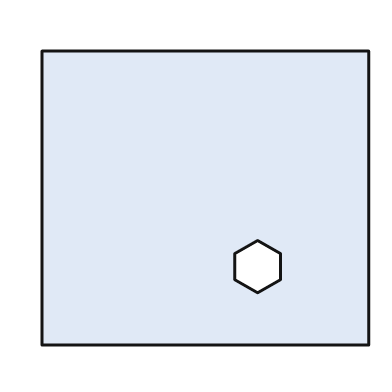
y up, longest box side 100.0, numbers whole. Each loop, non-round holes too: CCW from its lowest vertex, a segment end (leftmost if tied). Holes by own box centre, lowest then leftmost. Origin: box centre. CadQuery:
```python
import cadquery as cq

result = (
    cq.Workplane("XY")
    .moveTo(-50.0, -45.0)
    .lineTo(50.0, -45.0)
    .lineTo(50.0, 45.0)
    .lineTo(-50.0, 45.0)
    .close()
    .moveTo(16.0, -29.0)
    .lineTo(23.0, -25.0)
    .lineTo(23.0, -17.0)
    .lineTo(16.0, -13.0)
    .lineTo(9.0, -17.0)
    .lineTo(9.0, -25.0)
    .close()
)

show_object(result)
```